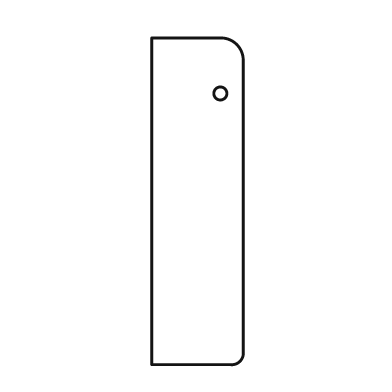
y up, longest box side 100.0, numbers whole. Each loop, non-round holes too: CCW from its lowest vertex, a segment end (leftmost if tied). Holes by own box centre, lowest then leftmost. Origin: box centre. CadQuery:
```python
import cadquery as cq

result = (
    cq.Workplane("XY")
    .moveTo(-14.0, -50.0)
    .lineTo(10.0, -50.0)
    .threePointArc((13.0, -49.0), (14.0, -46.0))
    .lineTo(14.0, 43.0)
    .threePointArc((12.0, 48.0), (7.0, 50.0))
    .lineTo(-14.0, 50.0)
    .close()
    .moveTo(7.0, 33.0)
    .circle(2.0)
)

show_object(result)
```